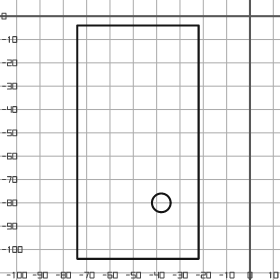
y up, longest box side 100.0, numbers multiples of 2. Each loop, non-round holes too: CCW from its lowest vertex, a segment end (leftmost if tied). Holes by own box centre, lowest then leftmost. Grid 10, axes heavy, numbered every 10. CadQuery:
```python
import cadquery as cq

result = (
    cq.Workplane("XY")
    .moveTo(-74.0, -104.0)
    .lineTo(-22.0, -104.0)
    .lineTo(-22.0, -4.0)
    .lineTo(-74.0, -4.0)
    .close()
    .moveTo(-38.0, -80.0)
    .circle(4.0)
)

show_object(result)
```